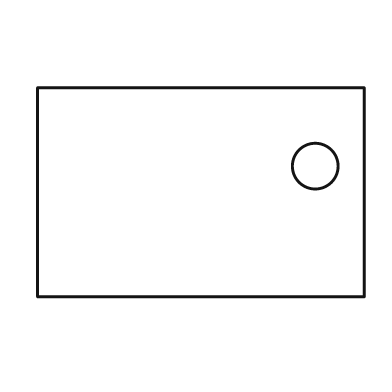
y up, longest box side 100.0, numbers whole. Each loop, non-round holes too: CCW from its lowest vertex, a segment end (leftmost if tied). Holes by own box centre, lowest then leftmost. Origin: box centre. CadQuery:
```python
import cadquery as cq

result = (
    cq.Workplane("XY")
    .moveTo(-50.0, -32.0)
    .lineTo(50.0, -32.0)
    .lineTo(50.0, 32.0)
    .lineTo(-50.0, 32.0)
    .close()
    .moveTo(35.0, 8.0)
    .circle(7.0)
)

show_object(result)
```